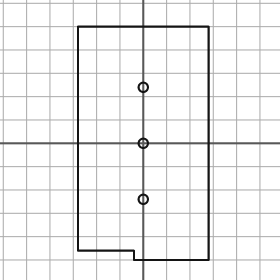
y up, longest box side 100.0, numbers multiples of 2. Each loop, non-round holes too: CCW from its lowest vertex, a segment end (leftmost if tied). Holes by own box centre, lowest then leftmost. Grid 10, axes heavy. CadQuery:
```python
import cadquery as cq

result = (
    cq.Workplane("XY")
    .moveTo(-4.0, -50.0)
    .lineTo(28.0, -50.0)
    .lineTo(28.0, 50.0)
    .lineTo(-28.0, 50.0)
    .lineTo(-28.0, -46.0)
    .lineTo(-4.0, -46.0)
    .close()
    .moveTo(0.0, -24.0)
    .circle(2.0)
    .moveTo(0.0, 0.0)
    .circle(2.0)
    .moveTo(0.0, 24.0)
    .circle(2.0)
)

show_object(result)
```